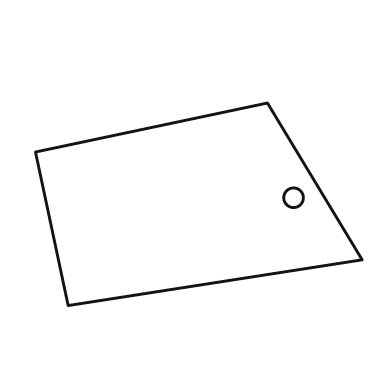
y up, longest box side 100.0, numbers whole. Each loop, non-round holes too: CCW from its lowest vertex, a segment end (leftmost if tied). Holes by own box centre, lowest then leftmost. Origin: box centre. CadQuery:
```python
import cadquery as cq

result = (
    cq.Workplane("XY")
    .moveTo(-40.0, -31.0)
    .lineTo(50.0, -17.0)
    .lineTo(21.0, 31.0)
    .lineTo(-50.0, 16.0)
    .close()
    .moveTo(29.0, 2.0)
    .circle(3.0)
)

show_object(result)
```